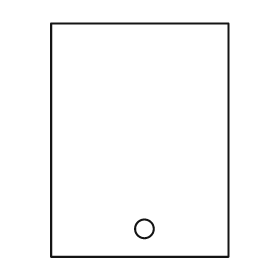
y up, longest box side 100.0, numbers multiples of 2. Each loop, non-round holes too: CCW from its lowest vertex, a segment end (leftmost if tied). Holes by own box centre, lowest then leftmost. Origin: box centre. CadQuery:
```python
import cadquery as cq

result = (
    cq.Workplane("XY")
    .moveTo(-38.0, -50.0)
    .lineTo(38.0, -50.0)
    .lineTo(38.0, 50.0)
    .lineTo(-38.0, 50.0)
    .close()
    .moveTo(2.0, -38.0)
    .circle(4.0)
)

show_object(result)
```